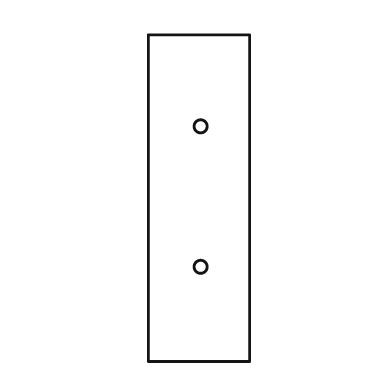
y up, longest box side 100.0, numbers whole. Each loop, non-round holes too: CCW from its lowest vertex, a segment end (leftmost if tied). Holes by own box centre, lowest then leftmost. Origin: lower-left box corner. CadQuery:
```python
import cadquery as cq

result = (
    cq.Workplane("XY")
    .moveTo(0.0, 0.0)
    .lineTo(31.0, 0.0)
    .lineTo(31.0, 100.0)
    .lineTo(0.0, 100.0)
    .close()
    .moveTo(16.0, 29.0)
    .circle(2.0)
    .moveTo(16.0, 72.0)
    .circle(2.0)
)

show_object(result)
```